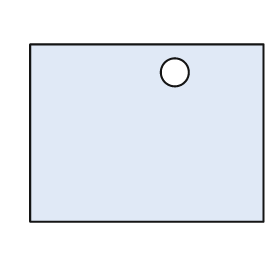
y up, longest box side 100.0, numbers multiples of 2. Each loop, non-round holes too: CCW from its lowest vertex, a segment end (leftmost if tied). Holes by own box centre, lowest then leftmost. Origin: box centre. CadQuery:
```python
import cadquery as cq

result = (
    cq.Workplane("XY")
    .moveTo(-50.0, -38.0)
    .lineTo(50.0, -38.0)
    .lineTo(50.0, 38.0)
    .lineTo(-50.0, 38.0)
    .close()
    .moveTo(12.0, 26.0)
    .circle(6.0)
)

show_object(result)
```